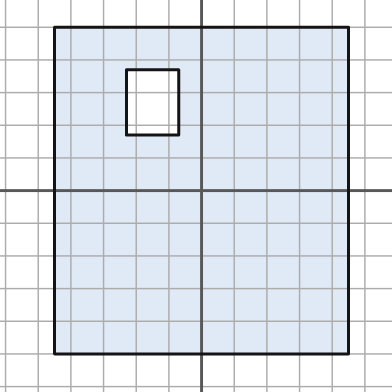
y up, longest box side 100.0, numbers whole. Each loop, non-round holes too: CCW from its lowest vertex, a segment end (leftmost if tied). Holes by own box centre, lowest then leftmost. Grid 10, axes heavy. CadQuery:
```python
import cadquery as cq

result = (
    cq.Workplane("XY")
    .moveTo(-45.0, -50.0)
    .lineTo(45.0, -50.0)
    .lineTo(45.0, 50.0)
    .lineTo(-45.0, 50.0)
    .close()
    .moveTo(-23.0, 17.0)
    .lineTo(-7.0, 17.0)
    .lineTo(-7.0, 37.0)
    .lineTo(-23.0, 37.0)
    .close()
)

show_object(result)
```